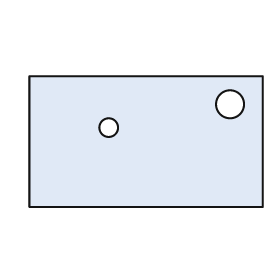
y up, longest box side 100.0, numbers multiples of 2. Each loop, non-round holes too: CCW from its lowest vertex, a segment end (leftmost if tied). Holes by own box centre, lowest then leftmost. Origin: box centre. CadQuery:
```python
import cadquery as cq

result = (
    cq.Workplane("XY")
    .moveTo(-50.0, -28.0)
    .lineTo(50.0, -28.0)
    .lineTo(50.0, 28.0)
    .lineTo(-50.0, 28.0)
    .close()
    .moveTo(-16.0, 6.0)
    .circle(4.0)
    .moveTo(36.0, 16.0)
    .circle(6.0)
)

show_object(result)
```